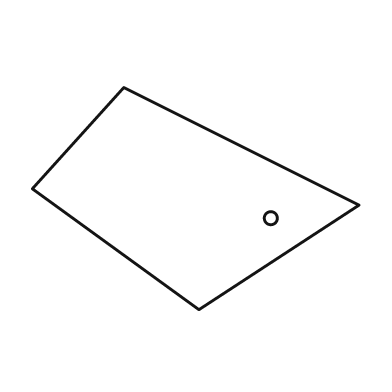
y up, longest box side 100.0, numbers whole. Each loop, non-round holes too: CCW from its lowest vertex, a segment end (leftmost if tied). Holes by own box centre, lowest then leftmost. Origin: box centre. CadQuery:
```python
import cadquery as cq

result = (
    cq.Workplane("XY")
    .moveTo(1.0, -34.0)
    .lineTo(50.0, -2.0)
    .lineTo(-22.0, 34.0)
    .lineTo(-50.0, 3.0)
    .close()
    .moveTo(23.0, -6.0)
    .circle(2.0)
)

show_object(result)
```